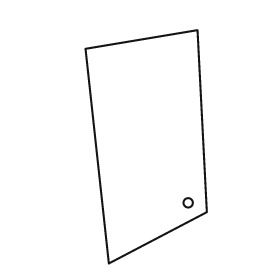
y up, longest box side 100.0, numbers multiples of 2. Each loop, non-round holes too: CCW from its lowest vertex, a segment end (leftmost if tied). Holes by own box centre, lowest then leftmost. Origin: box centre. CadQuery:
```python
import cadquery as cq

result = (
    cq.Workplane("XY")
    .moveTo(-16.0, -50.0)
    .lineTo(26.0, -28.0)
    .lineTo(22.0, 50.0)
    .lineTo(-26.0, 42.0)
    .close()
    .moveTo(18.0, -24.0)
    .circle(2.0)
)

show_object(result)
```